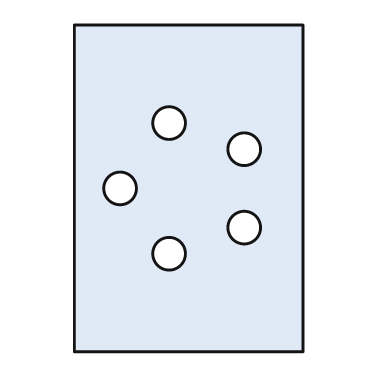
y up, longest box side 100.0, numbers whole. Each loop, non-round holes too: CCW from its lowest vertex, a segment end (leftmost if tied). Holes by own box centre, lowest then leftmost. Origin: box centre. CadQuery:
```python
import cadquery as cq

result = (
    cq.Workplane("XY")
    .moveTo(-35.0, -50.0)
    .lineTo(35.0, -50.0)
    .lineTo(35.0, 50.0)
    .lineTo(-35.0, 50.0)
    .close()
    .moveTo(-6.0, -20.0)
    .circle(5.0)
    .moveTo(17.0, -12.0)
    .circle(5.0)
    .moveTo(-21.0, 0.0)
    .circle(5.0)
    .moveTo(17.0, 12.0)
    .circle(5.0)
    .moveTo(-6.0, 20.0)
    .circle(5.0)
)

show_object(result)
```